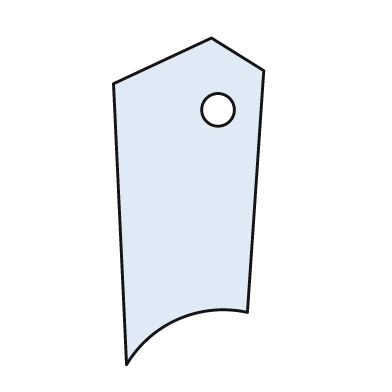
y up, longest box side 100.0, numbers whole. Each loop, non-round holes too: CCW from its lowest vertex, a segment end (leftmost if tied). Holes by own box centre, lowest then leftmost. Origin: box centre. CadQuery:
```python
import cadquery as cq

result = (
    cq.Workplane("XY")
    .moveTo(-19.0, -50.0)
    .threePointArc((-3.0, -36.0), (18.0, -34.0))
    .lineTo(23.0, 40.0)
    .lineTo(7.0, 50.0)
    .lineTo(-23.0, 36.0)
    .close()
    .moveTo(9.0, 28.0)
    .circle(5.0)
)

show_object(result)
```